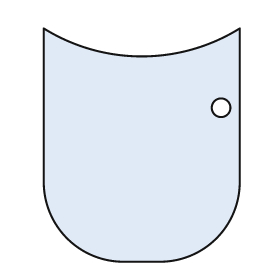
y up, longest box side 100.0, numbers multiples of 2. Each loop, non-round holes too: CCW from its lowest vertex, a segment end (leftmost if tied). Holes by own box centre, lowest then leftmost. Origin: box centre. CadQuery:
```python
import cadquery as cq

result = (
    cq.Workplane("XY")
    .moveTo(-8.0, -50.0)
    .lineTo(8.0, -50.0)
    .threePointArc((32.0, -40.0), (42.0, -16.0))
    .lineTo(42.0, 50.0)
    .threePointArc((0.0, 38.0), (-42.0, 50.0))
    .lineTo(-42.0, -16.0)
    .threePointArc((-32.0, -40.0), (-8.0, -50.0))
    .close()
    .moveTo(34.0, 16.0)
    .circle(4.0)
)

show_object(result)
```